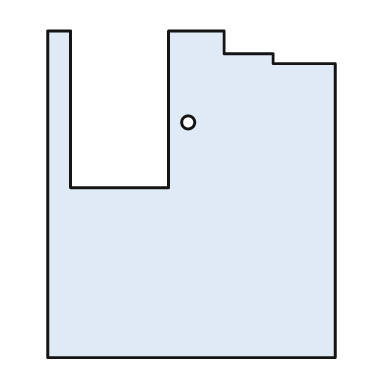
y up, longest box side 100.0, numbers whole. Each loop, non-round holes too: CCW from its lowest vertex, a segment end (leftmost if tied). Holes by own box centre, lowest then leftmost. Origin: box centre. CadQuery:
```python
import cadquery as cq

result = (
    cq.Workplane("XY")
    .moveTo(-44.0, -50.0)
    .lineTo(44.0, -50.0)
    .lineTo(44.0, 40.0)
    .lineTo(25.0, 40.0)
    .lineTo(25.0, 43.0)
    .lineTo(10.0, 43.0)
    .lineTo(10.0, 50.0)
    .lineTo(-7.0, 50.0)
    .lineTo(-7.0, 2.0)
    .lineTo(-37.0, 2.0)
    .lineTo(-37.0, 50.0)
    .lineTo(-44.0, 50.0)
    .close()
    .moveTo(-1.0, 22.0)
    .circle(2.0)
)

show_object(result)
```